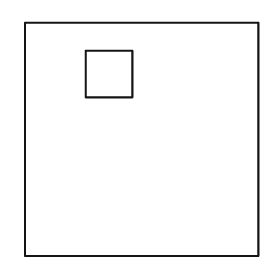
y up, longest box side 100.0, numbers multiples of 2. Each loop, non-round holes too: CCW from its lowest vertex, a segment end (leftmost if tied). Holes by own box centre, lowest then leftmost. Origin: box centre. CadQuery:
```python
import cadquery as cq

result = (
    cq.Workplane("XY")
    .moveTo(-50.0, -50.0)
    .lineTo(50.0, -50.0)
    .lineTo(50.0, 50.0)
    .lineTo(-50.0, 50.0)
    .close()
    .moveTo(-24.0, 18.0)
    .lineTo(-4.0, 18.0)
    .lineTo(-4.0, 38.0)
    .lineTo(-24.0, 38.0)
    .close()
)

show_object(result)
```